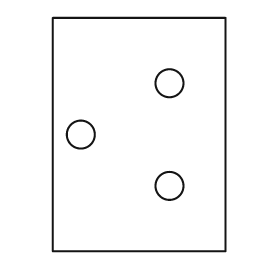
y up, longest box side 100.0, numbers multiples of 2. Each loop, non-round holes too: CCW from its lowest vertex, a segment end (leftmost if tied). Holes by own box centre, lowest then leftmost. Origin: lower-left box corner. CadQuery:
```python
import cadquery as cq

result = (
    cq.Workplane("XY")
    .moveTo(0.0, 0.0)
    .lineTo(74.0, 0.0)
    .lineTo(74.0, 100.0)
    .lineTo(0.0, 100.0)
    .close()
    .moveTo(50.0, 28.0)
    .circle(6.0)
    .moveTo(12.0, 50.0)
    .circle(6.0)
    .moveTo(50.0, 72.0)
    .circle(6.0)
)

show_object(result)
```